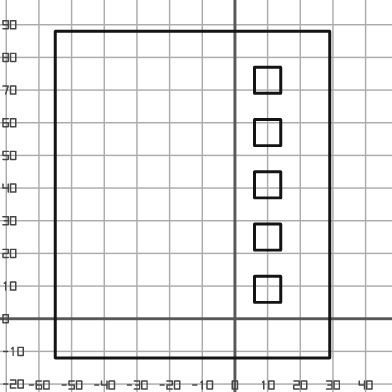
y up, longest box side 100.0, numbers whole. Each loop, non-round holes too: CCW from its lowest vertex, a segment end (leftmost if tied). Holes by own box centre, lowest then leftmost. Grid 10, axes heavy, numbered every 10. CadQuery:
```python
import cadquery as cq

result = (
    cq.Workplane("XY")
    .moveTo(-55.0, -12.0)
    .lineTo(29.0, -12.0)
    .lineTo(29.0, 88.0)
    .lineTo(-55.0, 88.0)
    .close()
    .moveTo(6.0, 5.0)
    .lineTo(14.0, 5.0)
    .lineTo(14.0, 13.0)
    .lineTo(6.0, 13.0)
    .close()
    .moveTo(6.0, 21.0)
    .lineTo(14.0, 21.0)
    .lineTo(14.0, 29.0)
    .lineTo(6.0, 29.0)
    .close()
    .moveTo(6.0, 37.0)
    .lineTo(14.0, 37.0)
    .lineTo(14.0, 45.0)
    .lineTo(6.0, 45.0)
    .close()
    .moveTo(6.0, 53.0)
    .lineTo(14.0, 53.0)
    .lineTo(14.0, 61.0)
    .lineTo(6.0, 61.0)
    .close()
    .moveTo(6.0, 69.0)
    .lineTo(14.0, 69.0)
    .lineTo(14.0, 77.0)
    .lineTo(6.0, 77.0)
    .close()
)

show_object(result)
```